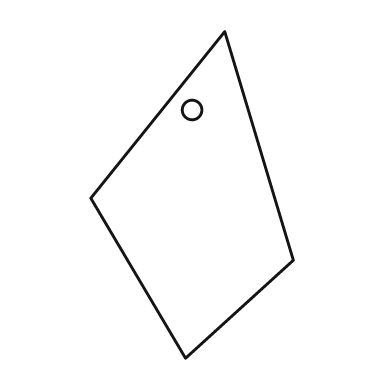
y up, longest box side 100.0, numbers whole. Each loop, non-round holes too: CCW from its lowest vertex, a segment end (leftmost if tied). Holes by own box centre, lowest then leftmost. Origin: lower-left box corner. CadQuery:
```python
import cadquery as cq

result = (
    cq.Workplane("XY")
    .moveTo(29.0, 0.0)
    .lineTo(62.0, 30.0)
    .lineTo(41.0, 100.0)
    .lineTo(0.0, 49.0)
    .close()
    .moveTo(31.0, 76.0)
    .circle(3.0)
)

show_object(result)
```